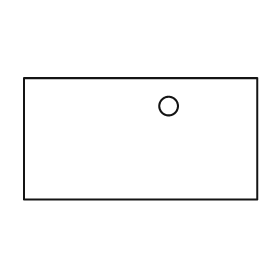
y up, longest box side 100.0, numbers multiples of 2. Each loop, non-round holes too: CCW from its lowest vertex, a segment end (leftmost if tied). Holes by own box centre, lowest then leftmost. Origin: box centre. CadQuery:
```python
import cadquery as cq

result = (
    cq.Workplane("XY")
    .moveTo(-50.0, -26.0)
    .lineTo(50.0, -26.0)
    .lineTo(50.0, 26.0)
    .lineTo(-50.0, 26.0)
    .close()
    .moveTo(12.0, 14.0)
    .circle(4.0)
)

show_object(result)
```